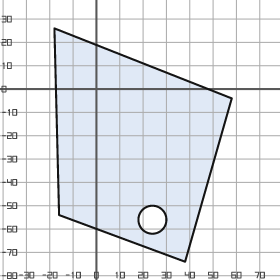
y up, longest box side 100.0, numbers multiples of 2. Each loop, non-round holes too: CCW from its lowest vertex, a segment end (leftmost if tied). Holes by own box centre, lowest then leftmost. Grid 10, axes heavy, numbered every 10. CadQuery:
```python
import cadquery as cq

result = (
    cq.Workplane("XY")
    .moveTo(38.0, -74.0)
    .lineTo(58.0, -4.0)
    .lineTo(-18.0, 26.0)
    .lineTo(-16.0, -54.0)
    .close()
    .moveTo(24.0, -56.0)
    .circle(6.0)
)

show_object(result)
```